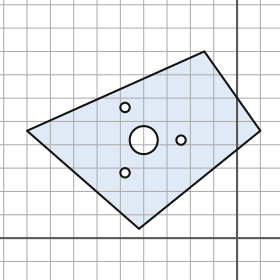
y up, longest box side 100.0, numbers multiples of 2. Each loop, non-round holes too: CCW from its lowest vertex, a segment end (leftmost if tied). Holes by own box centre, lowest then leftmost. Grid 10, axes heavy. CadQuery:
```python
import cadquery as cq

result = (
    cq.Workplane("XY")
    .moveTo(-42.0, 4.0)
    .lineTo(10.0, 46.0)
    .lineTo(-14.0, 80.0)
    .lineTo(-90.0, 46.0)
    .close()
    .moveTo(-48.0, 28.0)
    .circle(2.0)
    .moveTo(-40.0, 42.0)
    .circle(6.0)
    .moveTo(-24.0, 42.0)
    .circle(2.0)
    .moveTo(-48.0, 56.0)
    .circle(2.0)
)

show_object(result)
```